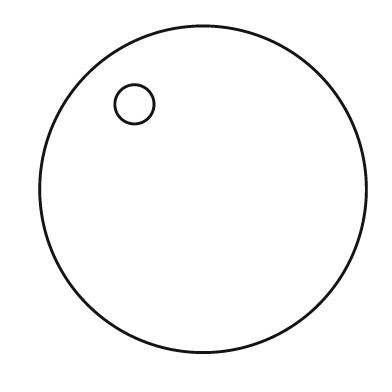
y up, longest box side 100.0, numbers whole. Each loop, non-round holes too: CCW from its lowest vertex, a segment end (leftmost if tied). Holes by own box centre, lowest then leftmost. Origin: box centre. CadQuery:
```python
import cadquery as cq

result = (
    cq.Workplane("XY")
    .moveTo(0.0, 0.0)
    .circle(50.0)
    .moveTo(-21.0, 26.0)
    .circle(6.0)
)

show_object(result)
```